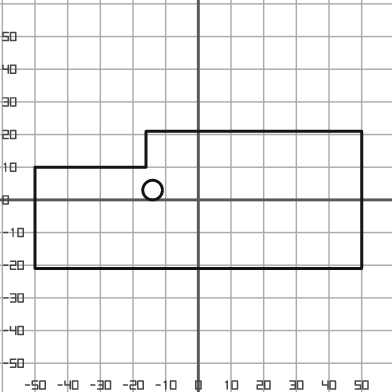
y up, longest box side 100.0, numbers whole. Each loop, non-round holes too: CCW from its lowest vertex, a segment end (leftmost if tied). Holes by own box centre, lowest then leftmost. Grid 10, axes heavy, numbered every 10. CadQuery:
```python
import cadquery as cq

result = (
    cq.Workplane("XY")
    .moveTo(-50.0, -21.0)
    .lineTo(50.0, -21.0)
    .lineTo(50.0, 21.0)
    .lineTo(-16.0, 21.0)
    .lineTo(-16.0, 10.0)
    .lineTo(-50.0, 10.0)
    .close()
    .moveTo(-14.0, 3.0)
    .circle(3.0)
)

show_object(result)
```